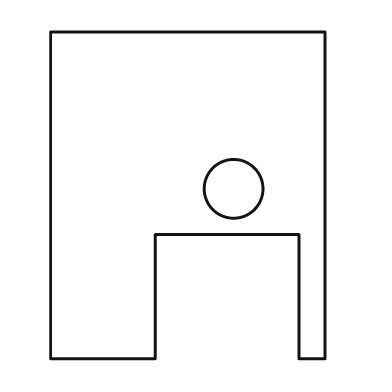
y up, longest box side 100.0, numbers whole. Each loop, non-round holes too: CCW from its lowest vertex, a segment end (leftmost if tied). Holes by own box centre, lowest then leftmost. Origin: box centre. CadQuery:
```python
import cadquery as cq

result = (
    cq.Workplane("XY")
    .moveTo(-42.0, -50.0)
    .lineTo(-10.0, -50.0)
    .lineTo(-10.0, -12.0)
    .lineTo(34.0, -12.0)
    .lineTo(34.0, -50.0)
    .lineTo(42.0, -50.0)
    .lineTo(42.0, 50.0)
    .lineTo(-42.0, 50.0)
    .close()
    .moveTo(14.0, 2.0)
    .circle(9.0)
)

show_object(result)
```